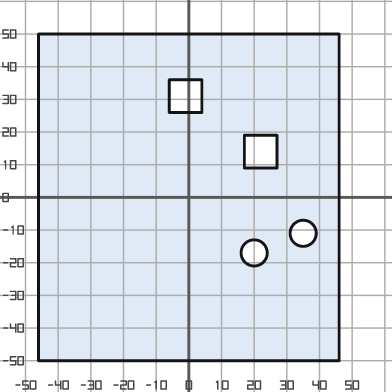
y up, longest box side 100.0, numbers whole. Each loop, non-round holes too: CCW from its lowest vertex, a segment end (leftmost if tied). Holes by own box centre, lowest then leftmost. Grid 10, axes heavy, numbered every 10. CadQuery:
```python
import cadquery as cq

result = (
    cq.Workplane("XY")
    .moveTo(-46.0, -50.0)
    .lineTo(46.0, -50.0)
    .lineTo(46.0, 50.0)
    .lineTo(-46.0, 50.0)
    .close()
    .moveTo(20.0, -17.0)
    .circle(4.0)
    .moveTo(35.0, -11.0)
    .circle(4.0)
    .moveTo(17.0, 9.0)
    .lineTo(27.0, 9.0)
    .lineTo(27.0, 19.0)
    .lineTo(17.0, 19.0)
    .close()
    .moveTo(-6.0, 26.0)
    .lineTo(4.0, 26.0)
    .lineTo(4.0, 36.0)
    .lineTo(-6.0, 36.0)
    .close()
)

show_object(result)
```